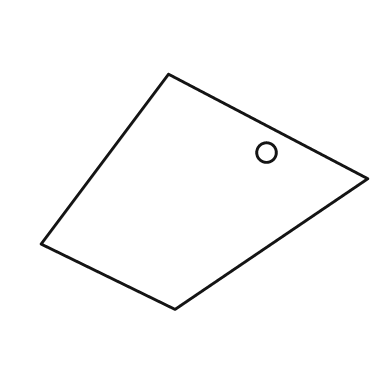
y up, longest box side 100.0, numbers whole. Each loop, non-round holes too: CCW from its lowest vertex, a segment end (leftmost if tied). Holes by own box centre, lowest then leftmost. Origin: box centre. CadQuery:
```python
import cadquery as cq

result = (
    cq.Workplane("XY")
    .moveTo(-9.0, -36.0)
    .lineTo(50.0, 4.0)
    .lineTo(-11.0, 36.0)
    .lineTo(-50.0, -16.0)
    .close()
    .moveTo(19.0, 12.0)
    .circle(3.0)
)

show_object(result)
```